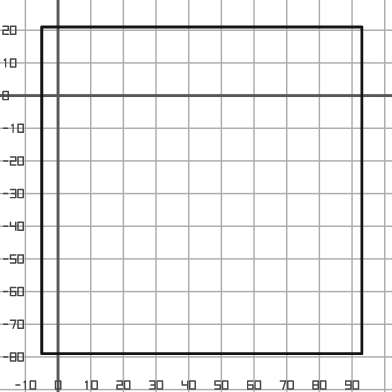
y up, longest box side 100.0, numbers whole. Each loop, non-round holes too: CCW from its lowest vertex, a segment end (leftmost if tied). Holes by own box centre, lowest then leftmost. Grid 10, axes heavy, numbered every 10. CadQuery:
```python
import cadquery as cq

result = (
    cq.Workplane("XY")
    .moveTo(-5.0, -79.0)
    .lineTo(93.0, -79.0)
    .lineTo(93.0, 21.0)
    .lineTo(-5.0, 21.0)
    .close()
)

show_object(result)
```